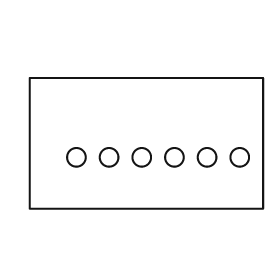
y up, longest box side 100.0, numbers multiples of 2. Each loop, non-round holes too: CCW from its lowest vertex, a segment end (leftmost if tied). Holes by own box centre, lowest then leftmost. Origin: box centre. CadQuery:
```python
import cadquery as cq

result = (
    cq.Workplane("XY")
    .moveTo(-50.0, -28.0)
    .lineTo(50.0, -28.0)
    .lineTo(50.0, 28.0)
    .lineTo(-50.0, 28.0)
    .close()
    .moveTo(-30.0, -6.0)
    .circle(4.0)
    .moveTo(-16.0, -6.0)
    .circle(4.0)
    .moveTo(-2.0, -6.0)
    .circle(4.0)
    .moveTo(12.0, -6.0)
    .circle(4.0)
    .moveTo(26.0, -6.0)
    .circle(4.0)
    .moveTo(40.0, -6.0)
    .circle(4.0)
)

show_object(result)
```